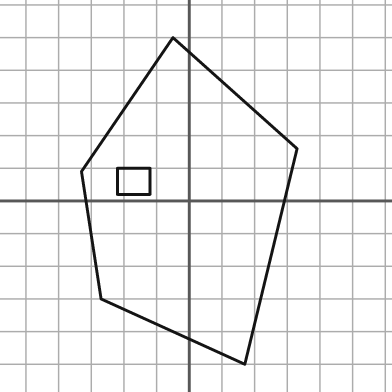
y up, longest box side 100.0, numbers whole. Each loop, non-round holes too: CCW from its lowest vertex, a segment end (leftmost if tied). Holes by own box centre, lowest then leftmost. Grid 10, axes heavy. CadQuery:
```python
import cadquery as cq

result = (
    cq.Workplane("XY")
    .moveTo(17.0, -50.0)
    .lineTo(33.0, 16.0)
    .lineTo(-5.0, 50.0)
    .lineTo(-33.0, 9.0)
    .lineTo(-27.0, -30.0)
    .close()
    .moveTo(-22.0, 2.0)
    .lineTo(-12.0, 2.0)
    .lineTo(-12.0, 10.0)
    .lineTo(-22.0, 10.0)
    .close()
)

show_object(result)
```